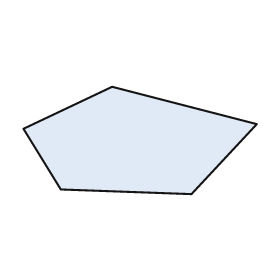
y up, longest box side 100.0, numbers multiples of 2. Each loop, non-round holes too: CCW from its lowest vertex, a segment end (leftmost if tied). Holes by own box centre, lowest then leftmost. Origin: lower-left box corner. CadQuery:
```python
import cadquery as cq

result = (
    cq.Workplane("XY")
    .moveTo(72.0, 0.0)
    .lineTo(100.0, 30.0)
    .lineTo(38.0, 46.0)
    .lineTo(0.0, 28.0)
    .lineTo(16.0, 2.0)
    .close()
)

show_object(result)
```